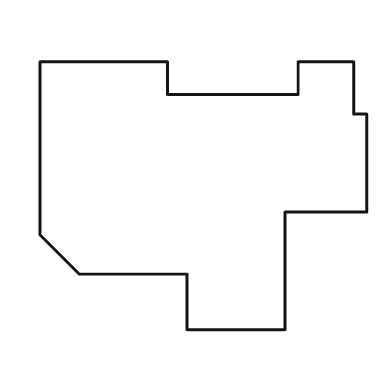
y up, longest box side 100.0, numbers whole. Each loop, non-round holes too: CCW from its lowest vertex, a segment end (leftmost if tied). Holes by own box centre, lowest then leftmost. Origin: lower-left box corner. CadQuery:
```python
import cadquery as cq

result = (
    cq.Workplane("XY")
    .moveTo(45.0, 0.0)
    .lineTo(75.0, 0.0)
    .lineTo(75.0, 36.0)
    .lineTo(100.0, 36.0)
    .lineTo(100.0, 66.0)
    .lineTo(96.0, 66.0)
    .lineTo(96.0, 82.0)
    .lineTo(79.0, 82.0)
    .lineTo(79.0, 72.0)
    .lineTo(39.0, 72.0)
    .lineTo(39.0, 82.0)
    .lineTo(0.0, 82.0)
    .lineTo(0.0, 29.0)
    .lineTo(12.0, 17.0)
    .lineTo(45.0, 17.0)
    .close()
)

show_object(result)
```